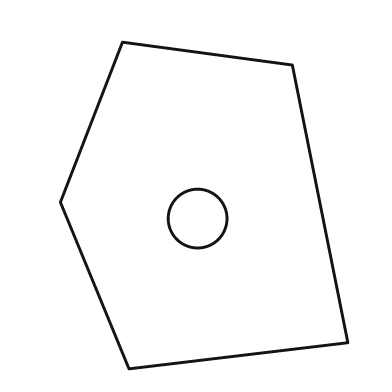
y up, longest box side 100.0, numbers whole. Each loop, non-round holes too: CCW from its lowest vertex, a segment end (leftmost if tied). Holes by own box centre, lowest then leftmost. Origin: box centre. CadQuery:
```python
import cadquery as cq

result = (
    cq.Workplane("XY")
    .moveTo(-23.0, -50.0)
    .lineTo(44.0, -42.0)
    .lineTo(27.0, 43.0)
    .lineTo(-25.0, 50.0)
    .lineTo(-44.0, 1.0)
    .close()
    .moveTo(-2.0, -4.0)
    .circle(9.0)
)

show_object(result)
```